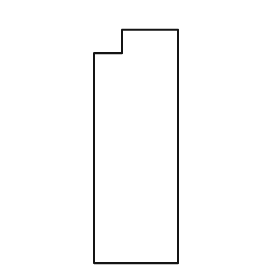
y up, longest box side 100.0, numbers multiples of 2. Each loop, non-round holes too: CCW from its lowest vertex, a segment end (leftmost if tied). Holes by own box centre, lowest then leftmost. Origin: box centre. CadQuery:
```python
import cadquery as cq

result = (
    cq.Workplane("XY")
    .moveTo(-18.0, -50.0)
    .lineTo(18.0, -50.0)
    .lineTo(18.0, 50.0)
    .lineTo(-6.0, 50.0)
    .lineTo(-6.0, 40.0)
    .lineTo(-18.0, 40.0)
    .close()
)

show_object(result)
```